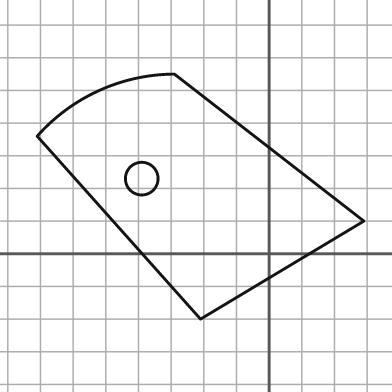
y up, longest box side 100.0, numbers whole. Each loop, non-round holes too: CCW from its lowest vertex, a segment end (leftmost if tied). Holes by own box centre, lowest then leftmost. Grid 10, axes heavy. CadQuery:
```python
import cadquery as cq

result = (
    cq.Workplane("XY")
    .moveTo(-21.0, -20.0)
    .lineTo(29.0, 10.0)
    .lineTo(-29.0, 55.0)
    .threePointArc((-52.0, 50.0), (-71.0, 36.0))
    .close()
    .moveTo(-39.0, 23.0)
    .circle(5.0)
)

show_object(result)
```